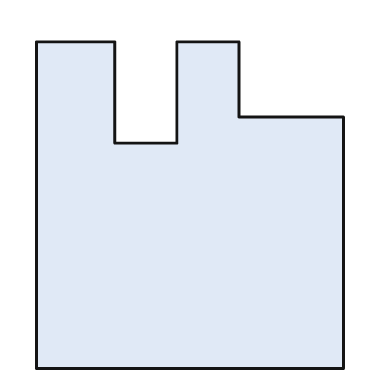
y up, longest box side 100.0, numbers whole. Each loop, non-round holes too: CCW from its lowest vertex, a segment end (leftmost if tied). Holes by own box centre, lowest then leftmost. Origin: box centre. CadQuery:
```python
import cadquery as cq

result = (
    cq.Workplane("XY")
    .moveTo(-47.0, -50.0)
    .lineTo(47.0, -50.0)
    .lineTo(47.0, 27.0)
    .lineTo(15.0, 27.0)
    .lineTo(15.0, 50.0)
    .lineTo(-4.0, 50.0)
    .lineTo(-4.0, 19.0)
    .lineTo(-23.0, 19.0)
    .lineTo(-23.0, 50.0)
    .lineTo(-47.0, 50.0)
    .close()
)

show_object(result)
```